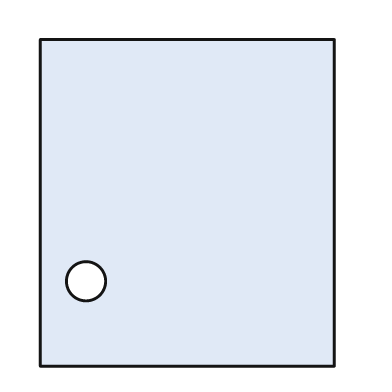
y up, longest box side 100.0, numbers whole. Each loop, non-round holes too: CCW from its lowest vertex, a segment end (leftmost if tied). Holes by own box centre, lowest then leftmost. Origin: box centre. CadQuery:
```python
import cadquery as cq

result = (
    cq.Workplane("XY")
    .moveTo(-45.0, -50.0)
    .lineTo(45.0, -50.0)
    .lineTo(45.0, 50.0)
    .lineTo(-45.0, 50.0)
    .close()
    .moveTo(-31.0, -24.0)
    .circle(6.0)
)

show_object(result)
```